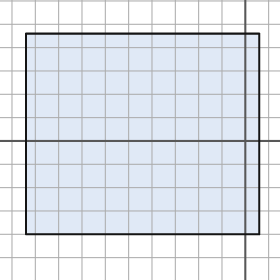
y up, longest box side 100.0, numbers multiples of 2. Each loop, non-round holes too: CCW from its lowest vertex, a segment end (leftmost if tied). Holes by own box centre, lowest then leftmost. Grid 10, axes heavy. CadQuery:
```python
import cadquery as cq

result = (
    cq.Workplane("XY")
    .moveTo(-94.0, -40.0)
    .lineTo(6.0, -40.0)
    .lineTo(6.0, 46.0)
    .lineTo(-94.0, 46.0)
    .close()
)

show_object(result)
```